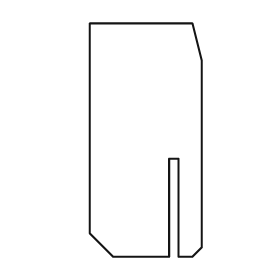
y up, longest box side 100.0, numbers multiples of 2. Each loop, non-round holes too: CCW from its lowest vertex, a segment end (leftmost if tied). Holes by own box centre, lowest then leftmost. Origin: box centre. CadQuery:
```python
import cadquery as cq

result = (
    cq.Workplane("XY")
    .moveTo(-14.0, -50.0)
    .lineTo(10.0, -50.0)
    .lineTo(10.0, -8.0)
    .lineTo(14.0, -8.0)
    .lineTo(14.0, -50.0)
    .lineTo(20.0, -50.0)
    .lineTo(24.0, -46.0)
    .lineTo(24.0, 34.0)
    .lineTo(20.0, 50.0)
    .lineTo(-24.0, 50.0)
    .lineTo(-24.0, -40.0)
    .close()
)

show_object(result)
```